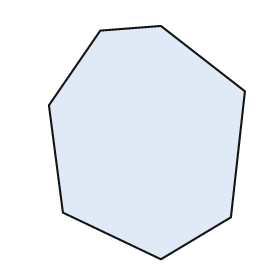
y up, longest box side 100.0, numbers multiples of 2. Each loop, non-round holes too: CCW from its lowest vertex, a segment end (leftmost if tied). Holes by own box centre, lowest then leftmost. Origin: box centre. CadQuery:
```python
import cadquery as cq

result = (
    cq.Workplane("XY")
    .moveTo(6.0, -50.0)
    .lineTo(36.0, -32.0)
    .lineTo(42.0, 22.0)
    .lineTo(6.0, 50.0)
    .lineTo(-20.0, 48.0)
    .lineTo(-42.0, 16.0)
    .lineTo(-36.0, -30.0)
    .close()
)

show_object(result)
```